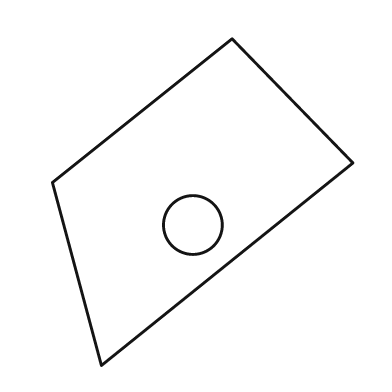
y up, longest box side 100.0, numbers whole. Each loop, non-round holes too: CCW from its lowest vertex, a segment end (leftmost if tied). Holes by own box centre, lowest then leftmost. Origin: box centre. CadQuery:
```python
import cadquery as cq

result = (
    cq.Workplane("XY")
    .moveTo(-31.0, -50.0)
    .lineTo(46.0, 12.0)
    .lineTo(9.0, 50.0)
    .lineTo(-46.0, 6.0)
    .close()
    .moveTo(-3.0, -7.0)
    .circle(9.0)
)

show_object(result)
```